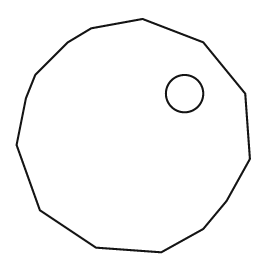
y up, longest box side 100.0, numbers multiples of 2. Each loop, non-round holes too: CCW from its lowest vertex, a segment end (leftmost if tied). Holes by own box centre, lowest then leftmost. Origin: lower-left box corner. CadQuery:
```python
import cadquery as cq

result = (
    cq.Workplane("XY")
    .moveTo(62.0, 0.0)
    .lineTo(80.0, 10.0)
    .lineTo(90.0, 22.0)
    .lineTo(100.0, 40.0)
    .lineTo(98.0, 68.0)
    .lineTo(80.0, 90.0)
    .lineTo(54.0, 100.0)
    .lineTo(32.0, 96.0)
    .lineTo(22.0, 90.0)
    .lineTo(8.0, 76.0)
    .lineTo(4.0, 66.0)
    .lineTo(0.0, 46.0)
    .lineTo(10.0, 18.0)
    .lineTo(34.0, 2.0)
    .close()
    .moveTo(72.0, 68.0)
    .circle(8.0)
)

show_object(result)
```